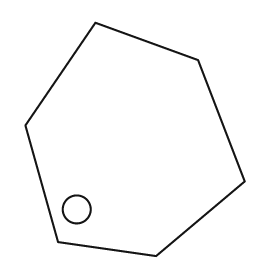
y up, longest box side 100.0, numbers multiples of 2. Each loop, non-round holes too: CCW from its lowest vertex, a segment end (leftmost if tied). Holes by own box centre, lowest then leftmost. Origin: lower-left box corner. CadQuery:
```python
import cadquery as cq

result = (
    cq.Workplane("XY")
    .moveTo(56.0, 0.0)
    .lineTo(94.0, 32.0)
    .lineTo(74.0, 84.0)
    .lineTo(30.0, 100.0)
    .lineTo(0.0, 56.0)
    .lineTo(14.0, 6.0)
    .close()
    .moveTo(22.0, 20.0)
    .circle(6.0)
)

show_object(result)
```